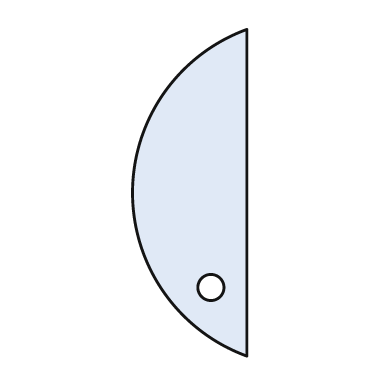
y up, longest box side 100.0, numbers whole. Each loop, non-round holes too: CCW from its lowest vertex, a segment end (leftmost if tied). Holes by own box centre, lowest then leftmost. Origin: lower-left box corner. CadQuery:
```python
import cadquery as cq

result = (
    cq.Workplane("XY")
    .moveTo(35.0, 0.0)
    .lineTo(35.0, 100.0)
    .threePointArc((0.0, 50.0), (35.0, 0.0))
    .close()
    .moveTo(24.0, 21.0)
    .circle(4.0)
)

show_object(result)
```